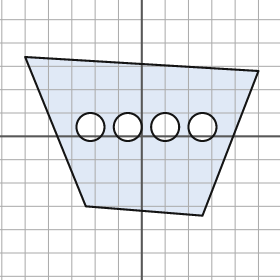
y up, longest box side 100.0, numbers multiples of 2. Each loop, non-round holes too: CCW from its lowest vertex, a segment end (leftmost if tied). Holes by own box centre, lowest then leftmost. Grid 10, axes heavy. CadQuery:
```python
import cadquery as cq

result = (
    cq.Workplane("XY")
    .moveTo(26.0, -34.0)
    .lineTo(50.0, 28.0)
    .lineTo(-50.0, 34.0)
    .lineTo(-24.0, -30.0)
    .close()
    .moveTo(-22.0, 4.0)
    .circle(6.0)
    .moveTo(-6.0, 4.0)
    .circle(6.0)
    .moveTo(10.0, 4.0)
    .circle(6.0)
    .moveTo(26.0, 4.0)
    .circle(6.0)
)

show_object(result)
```